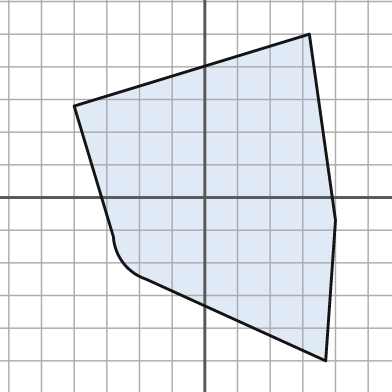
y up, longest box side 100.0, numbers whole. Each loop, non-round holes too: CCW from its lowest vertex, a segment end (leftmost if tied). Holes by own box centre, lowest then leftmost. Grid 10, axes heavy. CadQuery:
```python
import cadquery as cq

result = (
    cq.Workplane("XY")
    .moveTo(37.0, -50.0)
    .lineTo(40.0, -7.0)
    .lineTo(32.0, 50.0)
    .lineTo(-40.0, 28.0)
    .lineTo(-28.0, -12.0)
    .threePointArc((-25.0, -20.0), (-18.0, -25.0))
    .close()
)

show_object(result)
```